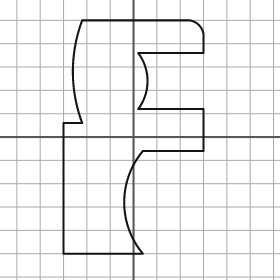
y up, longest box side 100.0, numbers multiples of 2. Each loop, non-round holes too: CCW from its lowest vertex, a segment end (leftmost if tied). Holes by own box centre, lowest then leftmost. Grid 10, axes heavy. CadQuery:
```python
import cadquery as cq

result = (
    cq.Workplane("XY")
    .moveTo(-30.0, -50.0)
    .lineTo(4.0, -50.0)
    .threePointArc((-4.0, -28.0), (4.0, -6.0))
    .lineTo(30.0, -6.0)
    .lineTo(30.0, 12.0)
    .lineTo(2.0, 12.0)
    .threePointArc((6.0, 24.0), (2.0, 36.0))
    .lineTo(30.0, 36.0)
    .lineTo(30.0, 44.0)
    .threePointArc((28.0, 48.0), (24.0, 50.0))
    .lineTo(-22.0, 50.0)
    .threePointArc((-26.0, 28.0), (-22.0, 6.0))
    .lineTo(-30.0, 6.0)
    .close()
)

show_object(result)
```